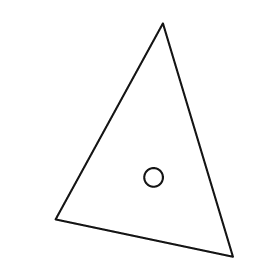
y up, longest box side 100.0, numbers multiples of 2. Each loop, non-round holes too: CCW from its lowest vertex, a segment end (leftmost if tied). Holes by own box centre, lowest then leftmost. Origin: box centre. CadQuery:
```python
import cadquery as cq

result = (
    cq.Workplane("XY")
    .moveTo(38.0, -50.0)
    .lineTo(8.0, 50.0)
    .lineTo(-38.0, -34.0)
    .close()
    .moveTo(4.0, -16.0)
    .circle(4.0)
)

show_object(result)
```